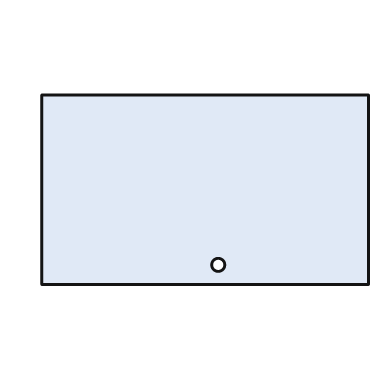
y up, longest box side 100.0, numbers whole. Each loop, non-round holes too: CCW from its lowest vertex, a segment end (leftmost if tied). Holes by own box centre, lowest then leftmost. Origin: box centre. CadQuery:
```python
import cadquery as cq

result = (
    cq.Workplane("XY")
    .moveTo(-50.0, -29.0)
    .lineTo(50.0, -29.0)
    .lineTo(50.0, 29.0)
    .lineTo(-50.0, 29.0)
    .close()
    .moveTo(4.0, -23.0)
    .circle(2.0)
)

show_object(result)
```